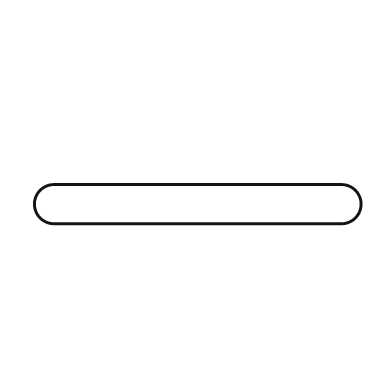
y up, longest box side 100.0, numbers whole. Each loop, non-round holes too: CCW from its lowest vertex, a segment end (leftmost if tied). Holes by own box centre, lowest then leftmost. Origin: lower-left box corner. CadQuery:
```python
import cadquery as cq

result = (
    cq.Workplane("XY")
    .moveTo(6.0, 0.0)
    .lineTo(94.0, 0.0)
    .threePointArc((100.0, 6.0), (94.0, 12.0))
    .lineTo(6.0, 12.0)
    .threePointArc((0.0, 6.0), (6.0, 0.0))
    .close()
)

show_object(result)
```